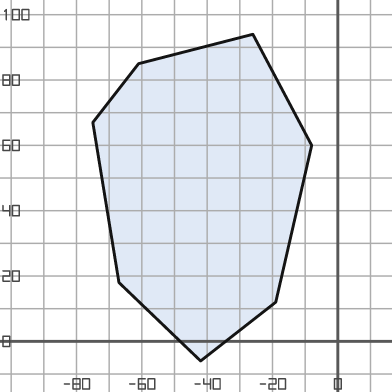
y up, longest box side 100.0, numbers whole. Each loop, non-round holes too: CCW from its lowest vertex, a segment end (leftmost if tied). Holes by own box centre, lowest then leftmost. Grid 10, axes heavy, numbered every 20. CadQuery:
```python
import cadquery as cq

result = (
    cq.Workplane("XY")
    .moveTo(-42.0, -6.0)
    .lineTo(-19.0, 12.0)
    .lineTo(-8.0, 60.0)
    .lineTo(-26.0, 94.0)
    .lineTo(-61.0, 85.0)
    .lineTo(-75.0, 67.0)
    .lineTo(-67.0, 18.0)
    .close()
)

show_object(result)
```